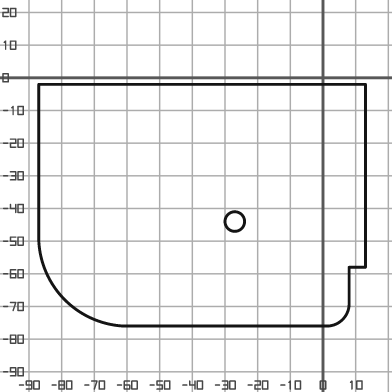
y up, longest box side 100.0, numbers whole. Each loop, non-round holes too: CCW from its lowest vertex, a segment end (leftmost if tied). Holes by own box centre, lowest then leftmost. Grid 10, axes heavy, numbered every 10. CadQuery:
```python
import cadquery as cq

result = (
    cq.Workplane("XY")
    .moveTo(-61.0, -76.0)
    .lineTo(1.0, -76.0)
    .threePointArc((6.0, -74.0), (8.0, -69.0))
    .lineTo(8.0, -58.0)
    .lineTo(13.0, -58.0)
    .lineTo(13.0, -2.0)
    .lineTo(-87.0, -2.0)
    .lineTo(-87.0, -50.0)
    .threePointArc((-79.0, -68.0), (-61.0, -76.0))
    .close()
    .moveTo(-27.0, -44.0)
    .circle(3.0)
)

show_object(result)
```